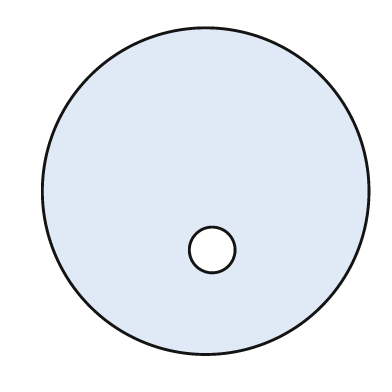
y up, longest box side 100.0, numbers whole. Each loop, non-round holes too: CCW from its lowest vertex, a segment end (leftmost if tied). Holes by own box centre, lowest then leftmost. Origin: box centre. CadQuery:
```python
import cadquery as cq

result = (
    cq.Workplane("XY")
    .moveTo(0.0, 0.0)
    .circle(50.0)
    .moveTo(2.0, -18.0)
    .circle(7.0)
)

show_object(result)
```